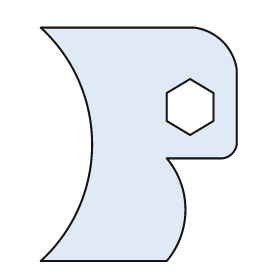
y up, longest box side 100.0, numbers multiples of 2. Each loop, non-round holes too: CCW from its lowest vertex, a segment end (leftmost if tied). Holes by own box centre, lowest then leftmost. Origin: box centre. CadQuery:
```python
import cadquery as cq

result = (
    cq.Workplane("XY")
    .moveTo(-42.0, -50.0)
    .lineTo(12.0, -50.0)
    .threePointArc((20.0, -28.0), (12.0, -6.0))
    .lineTo(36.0, -6.0)
    .threePointArc((40.0, -4.0), (42.0, 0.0))
    .lineTo(42.0, 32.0)
    .threePointArc((36.0, 44.0), (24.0, 50.0))
    .lineTo(-42.0, 50.0)
    .threePointArc((-20.0, 0.0), (-42.0, -50.0))
    .close()
    .moveTo(22.0, 4.0)
    .lineTo(32.0, 10.0)
    .lineTo(32.0, 22.0)
    .lineTo(22.0, 28.0)
    .lineTo(12.0, 22.0)
    .lineTo(12.0, 10.0)
    .close()
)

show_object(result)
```